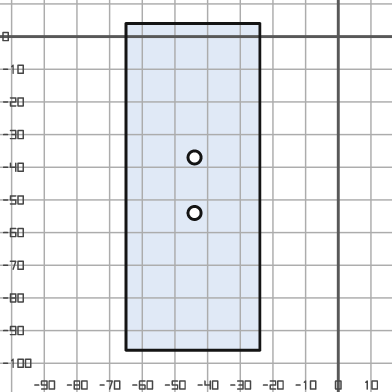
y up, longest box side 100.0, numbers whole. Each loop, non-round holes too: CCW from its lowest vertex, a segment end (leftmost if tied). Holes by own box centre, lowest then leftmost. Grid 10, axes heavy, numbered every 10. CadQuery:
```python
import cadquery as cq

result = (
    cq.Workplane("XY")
    .moveTo(-65.0, -96.0)
    .lineTo(-24.0, -96.0)
    .lineTo(-24.0, 4.0)
    .lineTo(-65.0, 4.0)
    .close()
    .moveTo(-44.0, -54.0)
    .circle(2.0)
    .moveTo(-44.0, -37.0)
    .circle(2.0)
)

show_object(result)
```